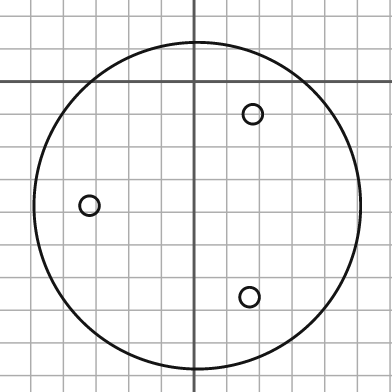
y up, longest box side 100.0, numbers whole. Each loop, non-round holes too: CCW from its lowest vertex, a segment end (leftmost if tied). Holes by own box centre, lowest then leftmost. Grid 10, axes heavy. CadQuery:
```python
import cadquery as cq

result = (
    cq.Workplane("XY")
    .moveTo(1.0, -38.0)
    .circle(50.0)
    .moveTo(17.0, -66.0)
    .circle(3.0)
    .moveTo(-32.0, -38.0)
    .circle(3.0)
    .moveTo(18.0, -10.0)
    .circle(3.0)
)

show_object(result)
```